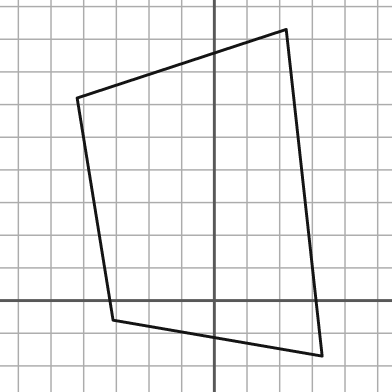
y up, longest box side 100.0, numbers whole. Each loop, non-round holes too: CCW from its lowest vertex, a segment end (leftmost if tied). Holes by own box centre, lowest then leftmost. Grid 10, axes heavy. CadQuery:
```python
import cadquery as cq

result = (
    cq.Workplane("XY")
    .moveTo(33.0, -17.0)
    .lineTo(22.0, 83.0)
    .lineTo(-42.0, 62.0)
    .lineTo(-31.0, -6.0)
    .close()
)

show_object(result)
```